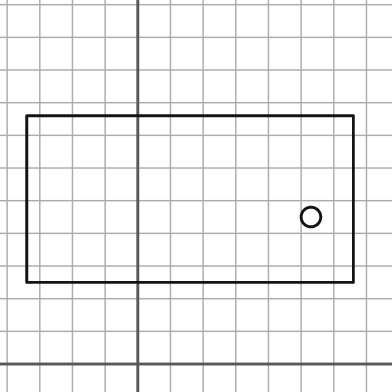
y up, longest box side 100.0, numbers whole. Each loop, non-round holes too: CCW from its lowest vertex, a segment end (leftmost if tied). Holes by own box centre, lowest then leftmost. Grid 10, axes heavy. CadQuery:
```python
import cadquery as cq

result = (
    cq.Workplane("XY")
    .moveTo(-34.0, 25.0)
    .lineTo(66.0, 25.0)
    .lineTo(66.0, 76.0)
    .lineTo(-34.0, 76.0)
    .close()
    .moveTo(53.0, 45.0)
    .circle(3.0)
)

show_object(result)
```